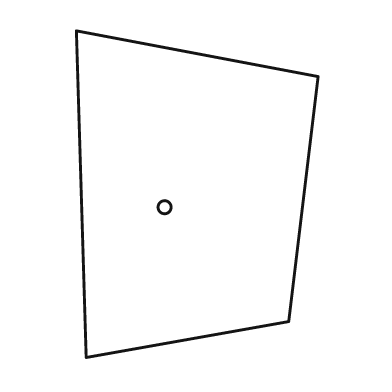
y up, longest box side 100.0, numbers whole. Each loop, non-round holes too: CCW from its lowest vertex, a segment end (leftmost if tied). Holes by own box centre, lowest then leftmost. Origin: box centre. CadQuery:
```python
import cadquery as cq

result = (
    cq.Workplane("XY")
    .moveTo(-34.0, -50.0)
    .lineTo(28.0, -39.0)
    .lineTo(37.0, 36.0)
    .lineTo(-37.0, 50.0)
    .close()
    .moveTo(-10.0, -4.0)
    .circle(2.0)
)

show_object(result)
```